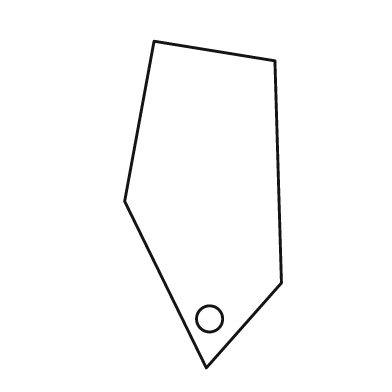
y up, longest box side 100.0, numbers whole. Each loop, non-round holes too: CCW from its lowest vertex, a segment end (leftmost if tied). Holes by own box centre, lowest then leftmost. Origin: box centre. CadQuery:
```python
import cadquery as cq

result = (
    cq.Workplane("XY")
    .moveTo(1.0, -50.0)
    .lineTo(24.0, -24.0)
    .lineTo(22.0, 44.0)
    .lineTo(-15.0, 50.0)
    .lineTo(-24.0, 1.0)
    .close()
    .moveTo(2.0, -35.0)
    .circle(4.0)
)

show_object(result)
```